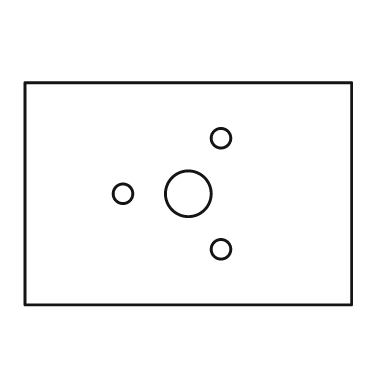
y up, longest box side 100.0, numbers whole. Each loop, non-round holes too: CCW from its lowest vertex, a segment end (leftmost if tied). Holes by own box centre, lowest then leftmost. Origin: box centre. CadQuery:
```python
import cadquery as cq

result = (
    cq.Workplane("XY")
    .moveTo(-50.0, -34.0)
    .lineTo(50.0, -34.0)
    .lineTo(50.0, 34.0)
    .lineTo(-50.0, 34.0)
    .close()
    .moveTo(10.0, -17.0)
    .circle(3.0)
    .moveTo(-20.0, 0.0)
    .circle(3.0)
    .moveTo(0.0, 0.0)
    .circle(7.0)
    .moveTo(10.0, 17.0)
    .circle(3.0)
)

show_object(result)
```